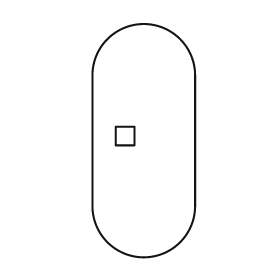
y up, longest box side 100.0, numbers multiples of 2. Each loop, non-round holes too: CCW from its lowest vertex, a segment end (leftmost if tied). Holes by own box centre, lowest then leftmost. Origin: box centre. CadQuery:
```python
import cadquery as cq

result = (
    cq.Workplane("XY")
    .moveTo(-22.0, -28.0)
    .threePointArc((0.0, -50.0), (22.0, -28.0))
    .lineTo(22.0, 28.0)
    .threePointArc((0.0, 50.0), (-22.0, 28.0))
    .close()
    .moveTo(-12.0, -2.0)
    .lineTo(-4.0, -2.0)
    .lineTo(-4.0, 6.0)
    .lineTo(-12.0, 6.0)
    .close()
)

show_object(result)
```